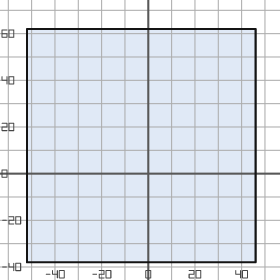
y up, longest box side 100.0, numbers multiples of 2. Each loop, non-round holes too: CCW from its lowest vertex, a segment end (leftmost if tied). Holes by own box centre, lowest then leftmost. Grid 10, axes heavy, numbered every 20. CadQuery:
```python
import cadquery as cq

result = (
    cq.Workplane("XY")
    .moveTo(-52.0, -38.0)
    .lineTo(46.0, -38.0)
    .lineTo(46.0, 62.0)
    .lineTo(-52.0, 62.0)
    .close()
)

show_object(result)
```